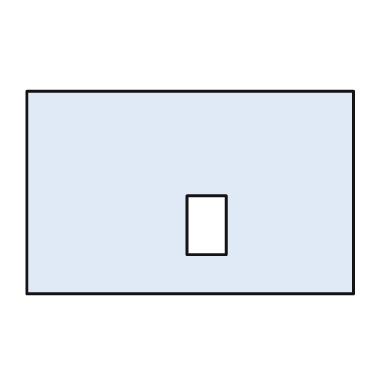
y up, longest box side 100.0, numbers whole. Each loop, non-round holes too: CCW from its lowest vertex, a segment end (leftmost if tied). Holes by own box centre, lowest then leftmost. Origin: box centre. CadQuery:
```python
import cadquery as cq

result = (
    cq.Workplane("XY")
    .moveTo(-50.0, -31.0)
    .lineTo(50.0, -31.0)
    .lineTo(50.0, 31.0)
    .lineTo(-50.0, 31.0)
    .close()
    .moveTo(-1.0, -19.0)
    .lineTo(11.0, -19.0)
    .lineTo(11.0, -1.0)
    .lineTo(-1.0, -1.0)
    .close()
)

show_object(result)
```